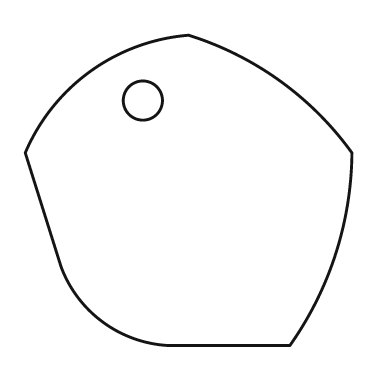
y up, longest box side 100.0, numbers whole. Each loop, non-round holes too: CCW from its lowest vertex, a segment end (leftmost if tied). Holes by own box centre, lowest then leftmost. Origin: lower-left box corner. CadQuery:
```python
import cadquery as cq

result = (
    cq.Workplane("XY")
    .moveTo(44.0, 0.0)
    .lineTo(81.0, 0.0)
    .threePointArc((95.0, 28.0), (100.0, 59.0))
    .threePointArc((78.0, 81.0), (50.0, 95.0))
    .threePointArc((20.0, 84.0), (0.0, 59.0))
    .lineTo(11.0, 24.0)
    .threePointArc((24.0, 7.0), (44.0, 0.0))
    .close()
    .moveTo(36.0, 75.0)
    .circle(6.0)
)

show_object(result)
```